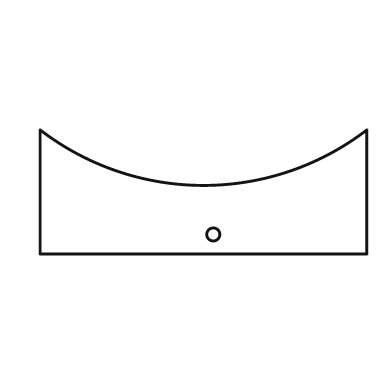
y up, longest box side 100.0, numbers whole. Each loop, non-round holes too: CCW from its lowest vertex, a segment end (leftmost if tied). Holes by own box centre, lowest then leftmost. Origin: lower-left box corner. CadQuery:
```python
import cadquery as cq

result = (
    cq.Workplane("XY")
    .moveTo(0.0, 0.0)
    .lineTo(100.0, 0.0)
    .lineTo(100.0, 38.0)
    .threePointArc((50.0, 21.0), (0.0, 38.0))
    .close()
    .moveTo(53.0, 6.0)
    .circle(2.0)
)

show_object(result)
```